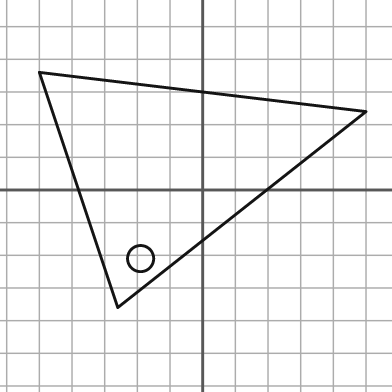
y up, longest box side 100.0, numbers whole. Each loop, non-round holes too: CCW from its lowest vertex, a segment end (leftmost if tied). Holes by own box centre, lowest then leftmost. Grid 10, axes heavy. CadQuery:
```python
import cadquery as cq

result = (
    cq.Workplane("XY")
    .moveTo(-26.0, -36.0)
    .lineTo(50.0, 24.0)
    .lineTo(-50.0, 36.0)
    .close()
    .moveTo(-19.0, -21.0)
    .circle(4.0)
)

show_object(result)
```